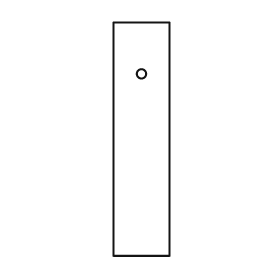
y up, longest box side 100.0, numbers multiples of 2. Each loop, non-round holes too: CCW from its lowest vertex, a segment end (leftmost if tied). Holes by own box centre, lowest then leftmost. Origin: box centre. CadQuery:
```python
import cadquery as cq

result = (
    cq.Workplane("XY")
    .moveTo(-12.0, -50.0)
    .lineTo(12.0, -50.0)
    .lineTo(12.0, 50.0)
    .lineTo(-12.0, 50.0)
    .close()
    .moveTo(0.0, 28.0)
    .circle(2.0)
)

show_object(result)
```